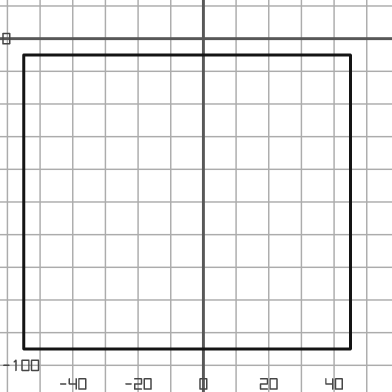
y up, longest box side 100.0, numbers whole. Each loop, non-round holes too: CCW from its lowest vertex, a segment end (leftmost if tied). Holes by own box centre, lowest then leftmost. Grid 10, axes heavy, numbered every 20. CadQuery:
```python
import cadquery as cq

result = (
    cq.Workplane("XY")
    .moveTo(-55.0, -95.0)
    .lineTo(45.0, -95.0)
    .lineTo(45.0, -5.0)
    .lineTo(-55.0, -5.0)
    .close()
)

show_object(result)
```